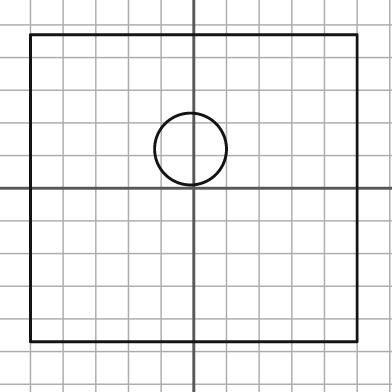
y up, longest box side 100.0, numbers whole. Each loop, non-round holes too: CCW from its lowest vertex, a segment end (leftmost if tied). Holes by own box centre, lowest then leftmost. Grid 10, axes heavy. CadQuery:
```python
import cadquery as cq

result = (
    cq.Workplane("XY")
    .moveTo(-50.0, -47.0)
    .lineTo(50.0, -47.0)
    .lineTo(50.0, 47.0)
    .lineTo(-50.0, 47.0)
    .close()
    .moveTo(-1.0, 12.0)
    .circle(11.0)
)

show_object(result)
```